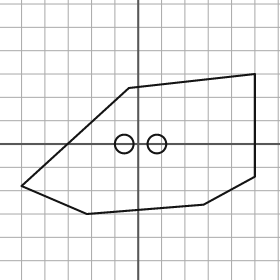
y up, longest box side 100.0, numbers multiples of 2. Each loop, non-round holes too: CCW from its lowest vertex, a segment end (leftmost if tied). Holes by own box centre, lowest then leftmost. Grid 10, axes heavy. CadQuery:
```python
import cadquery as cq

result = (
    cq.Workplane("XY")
    .moveTo(-22.0, -30.0)
    .lineTo(28.0, -26.0)
    .lineTo(50.0, -14.0)
    .lineTo(50.0, 30.0)
    .lineTo(-4.0, 24.0)
    .lineTo(-50.0, -18.0)
    .close()
    .moveTo(-6.0, 0.0)
    .circle(4.0)
    .moveTo(8.0, 0.0)
    .circle(4.0)
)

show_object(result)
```